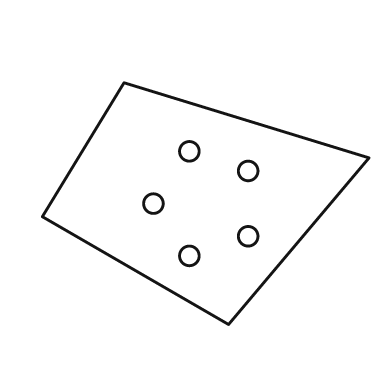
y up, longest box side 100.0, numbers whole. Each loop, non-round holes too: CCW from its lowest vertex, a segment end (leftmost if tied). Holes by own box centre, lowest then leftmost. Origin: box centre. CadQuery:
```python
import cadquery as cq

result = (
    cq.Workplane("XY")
    .moveTo(7.0, -37.0)
    .lineTo(50.0, 14.0)
    .lineTo(-25.0, 37.0)
    .lineTo(-50.0, -4.0)
    .close()
    .moveTo(-5.0, -16.0)
    .circle(3.0)
    .moveTo(13.0, -10.0)
    .circle(3.0)
    .moveTo(-16.0, 0.0)
    .circle(3.0)
    .moveTo(13.0, 10.0)
    .circle(3.0)
    .moveTo(-5.0, 16.0)
    .circle(3.0)
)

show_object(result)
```